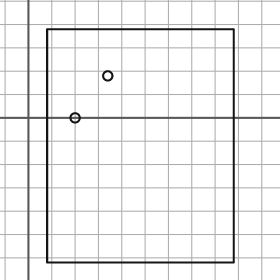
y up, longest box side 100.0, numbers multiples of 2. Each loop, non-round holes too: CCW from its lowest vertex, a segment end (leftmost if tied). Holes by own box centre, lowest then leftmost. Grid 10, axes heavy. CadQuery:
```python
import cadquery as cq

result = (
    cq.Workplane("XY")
    .moveTo(8.0, -62.0)
    .lineTo(88.0, -62.0)
    .lineTo(88.0, 38.0)
    .lineTo(8.0, 38.0)
    .close()
    .moveTo(20.0, 0.0)
    .circle(2.0)
    .moveTo(34.0, 18.0)
    .circle(2.0)
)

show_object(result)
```